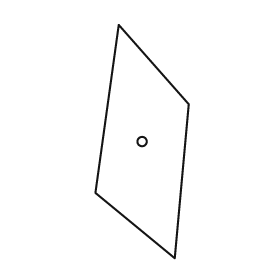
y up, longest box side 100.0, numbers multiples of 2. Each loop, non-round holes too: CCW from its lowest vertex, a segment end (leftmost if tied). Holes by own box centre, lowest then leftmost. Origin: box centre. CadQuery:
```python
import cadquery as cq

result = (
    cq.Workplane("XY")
    .moveTo(14.0, -50.0)
    .lineTo(20.0, 16.0)
    .lineTo(-10.0, 50.0)
    .lineTo(-20.0, -22.0)
    .close()
    .moveTo(0.0, 0.0)
    .circle(2.0)
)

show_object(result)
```